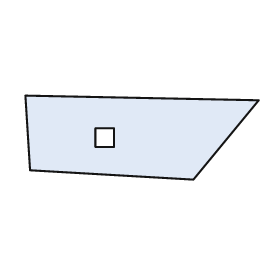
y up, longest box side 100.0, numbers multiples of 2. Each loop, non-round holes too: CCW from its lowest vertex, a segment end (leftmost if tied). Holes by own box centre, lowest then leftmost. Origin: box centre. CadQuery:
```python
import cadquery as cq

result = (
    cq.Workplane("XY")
    .moveTo(22.0, -18.0)
    .lineTo(50.0, 16.0)
    .lineTo(-50.0, 18.0)
    .lineTo(-48.0, -14.0)
    .close()
    .moveTo(-20.0, -4.0)
    .lineTo(-12.0, -4.0)
    .lineTo(-12.0, 4.0)
    .lineTo(-20.0, 4.0)
    .close()
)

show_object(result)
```